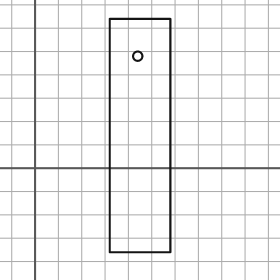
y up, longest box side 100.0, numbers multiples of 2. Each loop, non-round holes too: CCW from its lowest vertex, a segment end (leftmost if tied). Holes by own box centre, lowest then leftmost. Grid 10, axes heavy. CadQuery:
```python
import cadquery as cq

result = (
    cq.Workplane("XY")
    .moveTo(32.0, -36.0)
    .lineTo(58.0, -36.0)
    .lineTo(58.0, 64.0)
    .lineTo(32.0, 64.0)
    .close()
    .moveTo(44.0, 48.0)
    .circle(2.0)
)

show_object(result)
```